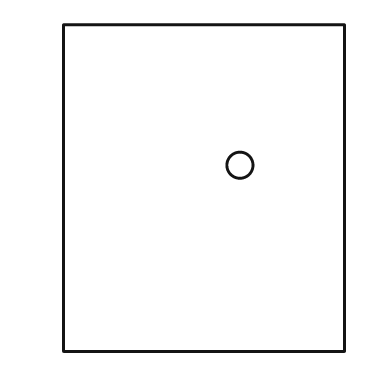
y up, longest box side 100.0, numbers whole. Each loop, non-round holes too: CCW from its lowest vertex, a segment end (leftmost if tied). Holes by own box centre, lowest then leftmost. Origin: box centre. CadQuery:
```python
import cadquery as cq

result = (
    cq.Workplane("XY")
    .moveTo(-43.0, -50.0)
    .lineTo(43.0, -50.0)
    .lineTo(43.0, 50.0)
    .lineTo(-43.0, 50.0)
    .close()
    .moveTo(11.0, 7.0)
    .circle(4.0)
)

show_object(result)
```